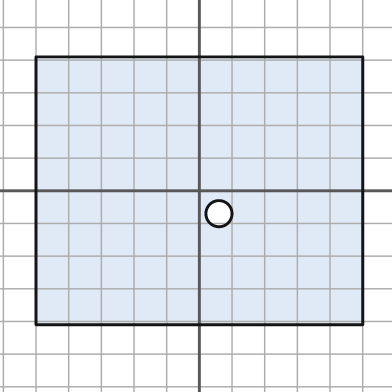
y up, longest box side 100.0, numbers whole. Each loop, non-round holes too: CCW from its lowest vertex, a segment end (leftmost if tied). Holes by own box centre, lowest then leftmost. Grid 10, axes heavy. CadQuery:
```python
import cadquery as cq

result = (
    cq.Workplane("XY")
    .moveTo(-50.0, -41.0)
    .lineTo(50.0, -41.0)
    .lineTo(50.0, 41.0)
    .lineTo(-50.0, 41.0)
    .close()
    .moveTo(6.0, -7.0)
    .circle(4.0)
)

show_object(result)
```